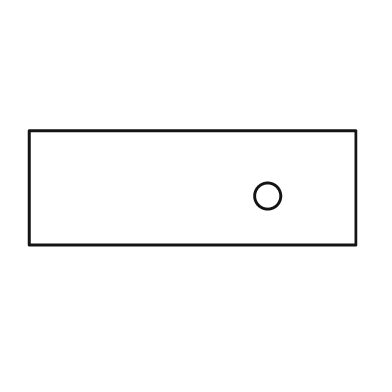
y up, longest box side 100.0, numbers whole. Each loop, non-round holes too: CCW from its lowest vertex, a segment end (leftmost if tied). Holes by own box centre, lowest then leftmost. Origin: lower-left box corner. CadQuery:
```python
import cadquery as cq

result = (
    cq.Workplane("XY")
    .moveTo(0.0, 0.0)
    .lineTo(100.0, 0.0)
    .lineTo(100.0, 35.0)
    .lineTo(0.0, 35.0)
    .close()
    .moveTo(73.0, 15.0)
    .circle(4.0)
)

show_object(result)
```